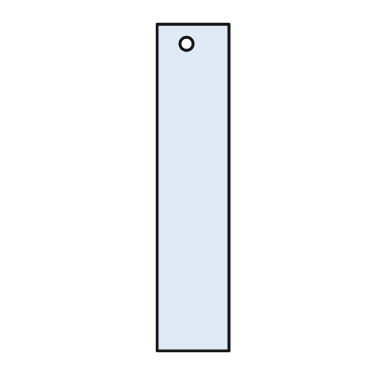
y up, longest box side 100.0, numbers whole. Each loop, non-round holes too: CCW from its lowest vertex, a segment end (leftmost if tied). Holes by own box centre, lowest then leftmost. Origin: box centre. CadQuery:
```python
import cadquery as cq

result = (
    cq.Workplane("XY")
    .moveTo(-11.0, -50.0)
    .lineTo(11.0, -50.0)
    .lineTo(11.0, 50.0)
    .lineTo(-11.0, 50.0)
    .close()
    .moveTo(-2.0, 44.0)
    .circle(2.0)
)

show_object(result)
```